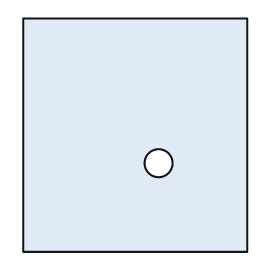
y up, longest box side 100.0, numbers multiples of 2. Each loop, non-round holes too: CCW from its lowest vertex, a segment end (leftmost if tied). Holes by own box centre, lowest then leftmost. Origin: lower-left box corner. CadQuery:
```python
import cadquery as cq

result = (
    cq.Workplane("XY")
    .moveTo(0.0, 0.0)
    .lineTo(96.0, 0.0)
    .lineTo(96.0, 100.0)
    .lineTo(0.0, 100.0)
    .close()
    .moveTo(58.0, 38.0)
    .circle(6.0)
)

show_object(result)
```